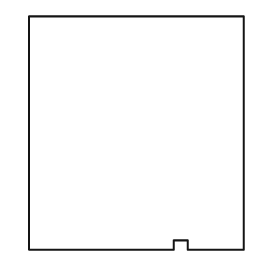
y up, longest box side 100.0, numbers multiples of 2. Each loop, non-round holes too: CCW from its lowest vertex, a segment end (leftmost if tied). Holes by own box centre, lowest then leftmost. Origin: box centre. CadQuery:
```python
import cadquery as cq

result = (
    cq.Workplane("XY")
    .moveTo(-46.0, -50.0)
    .lineTo(16.0, -50.0)
    .lineTo(16.0, -46.0)
    .lineTo(22.0, -46.0)
    .lineTo(22.0, -50.0)
    .lineTo(46.0, -50.0)
    .lineTo(46.0, 50.0)
    .lineTo(-46.0, 50.0)
    .close()
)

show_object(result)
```